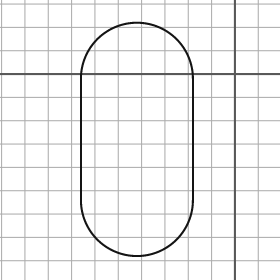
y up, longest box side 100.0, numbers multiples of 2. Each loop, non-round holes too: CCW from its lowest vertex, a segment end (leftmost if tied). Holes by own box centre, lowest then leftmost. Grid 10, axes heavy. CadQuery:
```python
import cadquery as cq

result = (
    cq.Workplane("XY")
    .moveTo(-66.0, -54.0)
    .threePointArc((-42.0, -78.0), (-18.0, -54.0))
    .lineTo(-18.0, -2.0)
    .threePointArc((-42.0, 22.0), (-66.0, -2.0))
    .close()
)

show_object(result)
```